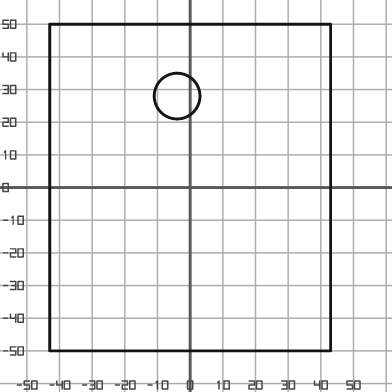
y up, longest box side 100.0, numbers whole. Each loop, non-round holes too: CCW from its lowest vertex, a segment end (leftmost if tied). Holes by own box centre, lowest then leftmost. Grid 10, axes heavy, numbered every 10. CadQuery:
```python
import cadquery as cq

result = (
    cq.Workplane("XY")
    .moveTo(-43.0, -50.0)
    .lineTo(43.0, -50.0)
    .lineTo(43.0, 50.0)
    .lineTo(-43.0, 50.0)
    .close()
    .moveTo(-4.0, 28.0)
    .circle(7.0)
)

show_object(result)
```